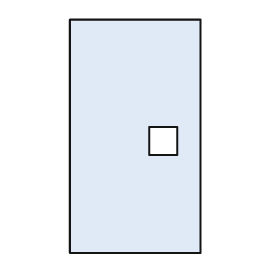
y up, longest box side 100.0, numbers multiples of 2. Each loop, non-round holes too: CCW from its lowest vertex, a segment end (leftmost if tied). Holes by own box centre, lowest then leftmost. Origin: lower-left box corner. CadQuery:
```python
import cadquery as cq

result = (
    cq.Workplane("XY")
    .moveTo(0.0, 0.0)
    .lineTo(56.0, 0.0)
    .lineTo(56.0, 100.0)
    .lineTo(0.0, 100.0)
    .close()
    .moveTo(34.0, 42.0)
    .lineTo(46.0, 42.0)
    .lineTo(46.0, 54.0)
    .lineTo(34.0, 54.0)
    .close()
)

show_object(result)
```